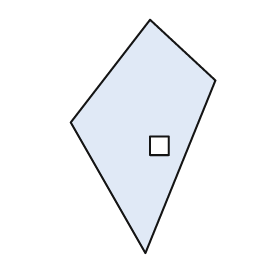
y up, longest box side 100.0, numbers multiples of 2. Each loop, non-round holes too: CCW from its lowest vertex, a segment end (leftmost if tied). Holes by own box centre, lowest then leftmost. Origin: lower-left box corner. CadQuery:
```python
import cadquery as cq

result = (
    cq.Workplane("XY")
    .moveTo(32.0, 0.0)
    .lineTo(62.0, 74.0)
    .lineTo(34.0, 100.0)
    .lineTo(0.0, 56.0)
    .close()
    .moveTo(34.0, 42.0)
    .lineTo(42.0, 42.0)
    .lineTo(42.0, 50.0)
    .lineTo(34.0, 50.0)
    .close()
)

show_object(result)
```